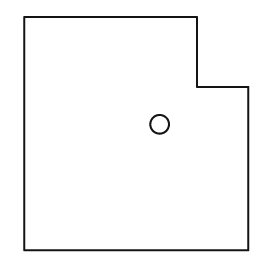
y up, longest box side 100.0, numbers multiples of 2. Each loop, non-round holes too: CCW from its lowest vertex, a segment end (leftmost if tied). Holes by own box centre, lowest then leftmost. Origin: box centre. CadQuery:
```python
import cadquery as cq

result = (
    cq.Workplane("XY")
    .moveTo(-48.0, -50.0)
    .lineTo(48.0, -50.0)
    .lineTo(48.0, 20.0)
    .lineTo(26.0, 20.0)
    .lineTo(26.0, 50.0)
    .lineTo(-48.0, 50.0)
    .close()
    .moveTo(10.0, 4.0)
    .circle(4.0)
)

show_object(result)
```